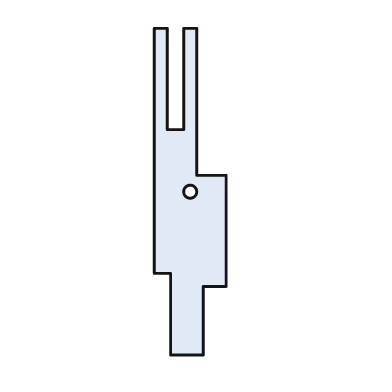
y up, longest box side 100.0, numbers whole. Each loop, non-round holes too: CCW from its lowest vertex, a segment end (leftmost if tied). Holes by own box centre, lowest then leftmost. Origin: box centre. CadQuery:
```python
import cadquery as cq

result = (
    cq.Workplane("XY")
    .moveTo(-6.0, -50.0)
    .lineTo(4.0, -50.0)
    .lineTo(4.0, -29.0)
    .lineTo(11.0, -29.0)
    .lineTo(11.0, 5.0)
    .lineTo(2.0, 5.0)
    .lineTo(2.0, 50.0)
    .lineTo(-2.0, 50.0)
    .lineTo(-2.0, 19.0)
    .lineTo(-7.0, 19.0)
    .lineTo(-7.0, 50.0)
    .lineTo(-11.0, 50.0)
    .lineTo(-11.0, -25.0)
    .lineTo(-6.0, -25.0)
    .close()
    .moveTo(0.0, 0.0)
    .circle(2.0)
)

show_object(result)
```